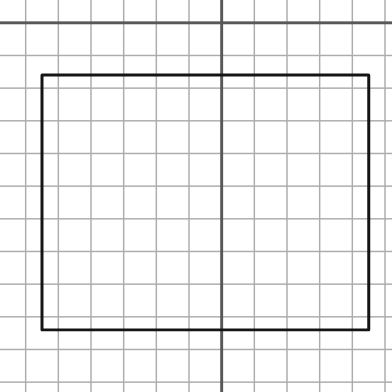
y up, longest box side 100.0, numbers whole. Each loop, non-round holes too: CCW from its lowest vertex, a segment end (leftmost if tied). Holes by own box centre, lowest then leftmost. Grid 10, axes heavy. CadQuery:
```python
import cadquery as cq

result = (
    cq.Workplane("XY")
    .moveTo(-55.0, -94.0)
    .lineTo(45.0, -94.0)
    .lineTo(45.0, -16.0)
    .lineTo(-55.0, -16.0)
    .close()
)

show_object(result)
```